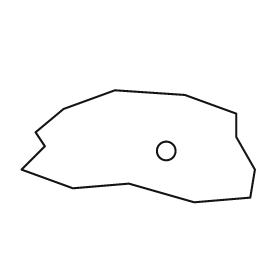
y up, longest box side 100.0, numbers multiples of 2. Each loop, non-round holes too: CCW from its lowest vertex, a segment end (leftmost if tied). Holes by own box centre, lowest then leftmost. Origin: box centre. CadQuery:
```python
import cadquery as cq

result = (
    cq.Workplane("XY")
    .moveTo(24.0, -24.0)
    .lineTo(48.0, -22.0)
    .lineTo(50.0, -10.0)
    .lineTo(42.0, 4.0)
    .lineTo(42.0, 14.0)
    .lineTo(20.0, 22.0)
    .lineTo(-10.0, 24.0)
    .lineTo(-32.0, 16.0)
    .lineTo(-44.0, 6.0)
    .lineTo(-40.0, 0.0)
    .lineTo(-50.0, -10.0)
    .lineTo(-28.0, -18.0)
    .lineTo(-4.0, -16.0)
    .close()
    .moveTo(12.0, -2.0)
    .circle(4.0)
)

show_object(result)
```